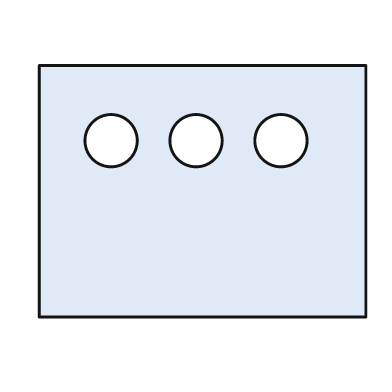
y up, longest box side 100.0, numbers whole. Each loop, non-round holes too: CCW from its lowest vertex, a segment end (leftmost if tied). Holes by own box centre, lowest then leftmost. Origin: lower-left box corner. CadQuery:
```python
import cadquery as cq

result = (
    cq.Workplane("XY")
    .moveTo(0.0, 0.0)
    .lineTo(100.0, 0.0)
    .lineTo(100.0, 77.0)
    .lineTo(0.0, 77.0)
    .close()
    .moveTo(22.0, 54.0)
    .circle(8.0)
    .moveTo(48.0, 54.0)
    .circle(8.0)
    .moveTo(74.0, 54.0)
    .circle(8.0)
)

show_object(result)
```